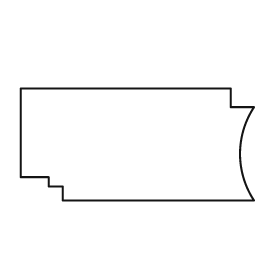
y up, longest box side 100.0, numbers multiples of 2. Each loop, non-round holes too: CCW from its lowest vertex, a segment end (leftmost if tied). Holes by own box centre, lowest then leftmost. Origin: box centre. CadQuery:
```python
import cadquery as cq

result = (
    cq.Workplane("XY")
    .moveTo(-32.0, -24.0)
    .lineTo(50.0, -24.0)
    .threePointArc((44.0, -4.0), (50.0, 16.0))
    .lineTo(40.0, 16.0)
    .lineTo(40.0, 24.0)
    .lineTo(-50.0, 24.0)
    .lineTo(-50.0, -14.0)
    .lineTo(-38.0, -14.0)
    .lineTo(-38.0, -18.0)
    .lineTo(-32.0, -18.0)
    .close()
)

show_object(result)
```